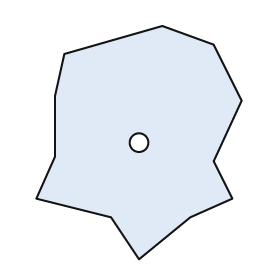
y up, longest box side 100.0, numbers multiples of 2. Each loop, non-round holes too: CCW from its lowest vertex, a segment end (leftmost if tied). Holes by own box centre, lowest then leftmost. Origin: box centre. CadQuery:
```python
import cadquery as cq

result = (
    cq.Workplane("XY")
    .moveTo(0.0, -50.0)
    .lineTo(22.0, -32.0)
    .lineTo(40.0, -24.0)
    .lineTo(32.0, -8.0)
    .lineTo(44.0, 18.0)
    .lineTo(32.0, 42.0)
    .lineTo(10.0, 50.0)
    .lineTo(-32.0, 38.0)
    .lineTo(-36.0, 20.0)
    .lineTo(-36.0, -6.0)
    .lineTo(-44.0, -24.0)
    .lineTo(-12.0, -32.0)
    .close()
    .moveTo(0.0, 0.0)
    .circle(4.0)
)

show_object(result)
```